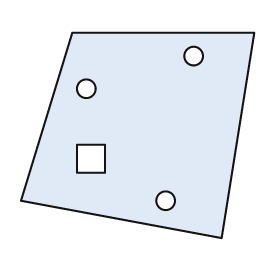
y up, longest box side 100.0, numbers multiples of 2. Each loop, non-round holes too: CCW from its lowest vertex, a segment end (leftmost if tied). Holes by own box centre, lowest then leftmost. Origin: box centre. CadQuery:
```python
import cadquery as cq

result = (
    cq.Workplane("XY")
    .moveTo(36.0, -44.0)
    .lineTo(50.0, 44.0)
    .lineTo(-28.0, 44.0)
    .lineTo(-50.0, -28.0)
    .close()
    .moveTo(12.0, -28.0)
    .circle(4.0)
    .moveTo(-26.0, -16.0)
    .lineTo(-14.0, -16.0)
    .lineTo(-14.0, -4.0)
    .lineTo(-26.0, -4.0)
    .close()
    .moveTo(-22.0, 20.0)
    .circle(4.0)
    .moveTo(24.0, 34.0)
    .circle(4.0)
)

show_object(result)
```